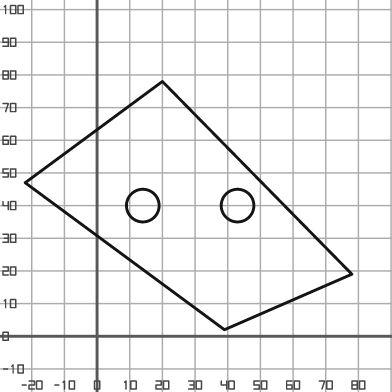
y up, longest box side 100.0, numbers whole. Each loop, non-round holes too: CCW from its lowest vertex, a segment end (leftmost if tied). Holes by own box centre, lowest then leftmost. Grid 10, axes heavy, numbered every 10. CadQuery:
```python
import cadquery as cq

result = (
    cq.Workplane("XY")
    .moveTo(39.0, 2.0)
    .lineTo(78.0, 19.0)
    .lineTo(20.0, 78.0)
    .lineTo(-22.0, 47.0)
    .close()
    .moveTo(14.0, 40.0)
    .circle(5.0)
    .moveTo(43.0, 40.0)
    .circle(5.0)
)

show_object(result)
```